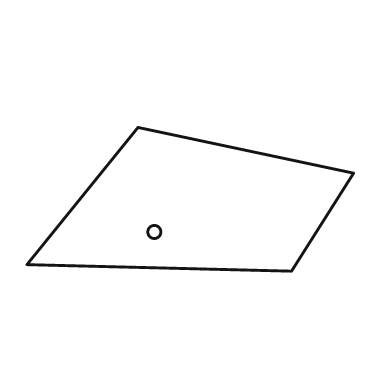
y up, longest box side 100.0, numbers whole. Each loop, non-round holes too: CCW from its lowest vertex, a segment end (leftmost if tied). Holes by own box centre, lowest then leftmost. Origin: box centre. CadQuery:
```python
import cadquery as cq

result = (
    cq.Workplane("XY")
    .moveTo(31.0, -22.0)
    .lineTo(50.0, 8.0)
    .lineTo(-16.0, 22.0)
    .lineTo(-50.0, -20.0)
    .close()
    .moveTo(-11.0, -10.0)
    .circle(2.0)
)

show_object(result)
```